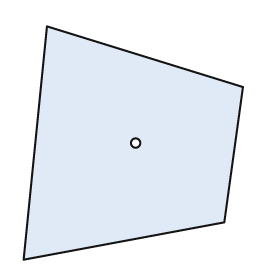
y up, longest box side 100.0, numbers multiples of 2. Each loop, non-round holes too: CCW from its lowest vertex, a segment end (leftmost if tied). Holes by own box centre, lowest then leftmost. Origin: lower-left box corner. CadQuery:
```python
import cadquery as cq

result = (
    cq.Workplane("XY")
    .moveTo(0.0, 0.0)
    .lineTo(86.0, 16.0)
    .lineTo(94.0, 74.0)
    .lineTo(10.0, 100.0)
    .close()
    .moveTo(48.0, 50.0)
    .circle(2.0)
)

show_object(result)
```